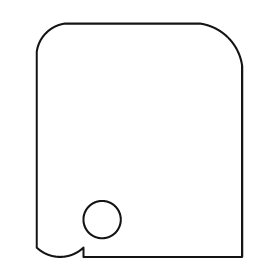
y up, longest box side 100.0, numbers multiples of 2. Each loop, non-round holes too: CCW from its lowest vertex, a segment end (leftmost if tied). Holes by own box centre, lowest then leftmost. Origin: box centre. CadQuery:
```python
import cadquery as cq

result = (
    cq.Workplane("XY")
    .moveTo(-24.0, -50.0)
    .lineTo(44.0, -50.0)
    .lineTo(44.0, 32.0)
    .threePointArc((38.0, 44.0), (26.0, 50.0))
    .lineTo(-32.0, 50.0)
    .threePointArc((-40.0, 46.0), (-44.0, 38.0))
    .lineTo(-44.0, -46.0)
    .threePointArc((-34.0, -50.0), (-24.0, -46.0))
    .close()
    .moveTo(-16.0, -34.0)
    .circle(8.0)
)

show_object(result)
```